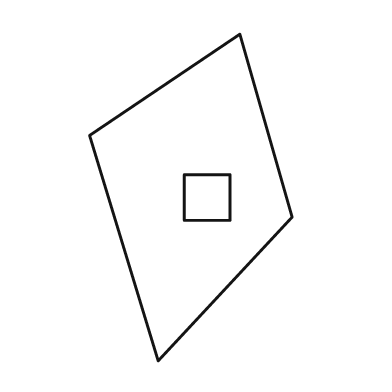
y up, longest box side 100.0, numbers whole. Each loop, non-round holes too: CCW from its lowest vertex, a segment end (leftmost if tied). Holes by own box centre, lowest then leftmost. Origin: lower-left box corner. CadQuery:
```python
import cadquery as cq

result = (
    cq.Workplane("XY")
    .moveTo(21.0, 0.0)
    .lineTo(62.0, 44.0)
    .lineTo(46.0, 100.0)
    .lineTo(0.0, 69.0)
    .close()
    .moveTo(29.0, 43.0)
    .lineTo(43.0, 43.0)
    .lineTo(43.0, 57.0)
    .lineTo(29.0, 57.0)
    .close()
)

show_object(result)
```